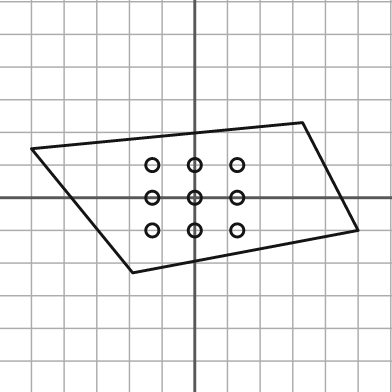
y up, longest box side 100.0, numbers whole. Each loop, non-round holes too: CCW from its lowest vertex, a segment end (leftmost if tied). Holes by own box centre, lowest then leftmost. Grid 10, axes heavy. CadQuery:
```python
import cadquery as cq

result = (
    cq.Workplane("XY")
    .moveTo(-19.0, -23.0)
    .lineTo(50.0, -10.0)
    .lineTo(33.0, 23.0)
    .lineTo(-50.0, 15.0)
    .close()
    .moveTo(-13.0, -10.0)
    .circle(2.0)
    .moveTo(0.0, -10.0)
    .circle(2.0)
    .moveTo(13.0, -10.0)
    .circle(2.0)
    .moveTo(-13.0, 0.0)
    .circle(2.0)
    .moveTo(0.0, 0.0)
    .circle(2.0)
    .moveTo(13.0, 0.0)
    .circle(2.0)
    .moveTo(-13.0, 10.0)
    .circle(2.0)
    .moveTo(0.0, 10.0)
    .circle(2.0)
    .moveTo(13.0, 10.0)
    .circle(2.0)
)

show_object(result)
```